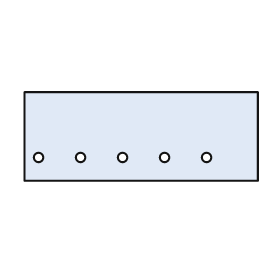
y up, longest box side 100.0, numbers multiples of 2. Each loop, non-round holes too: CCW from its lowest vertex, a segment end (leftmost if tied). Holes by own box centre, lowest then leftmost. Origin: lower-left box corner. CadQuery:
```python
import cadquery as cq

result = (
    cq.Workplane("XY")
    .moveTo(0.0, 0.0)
    .lineTo(100.0, 0.0)
    .lineTo(100.0, 38.0)
    .lineTo(0.0, 38.0)
    .close()
    .moveTo(6.0, 10.0)
    .circle(2.0)
    .moveTo(24.0, 10.0)
    .circle(2.0)
    .moveTo(42.0, 10.0)
    .circle(2.0)
    .moveTo(60.0, 10.0)
    .circle(2.0)
    .moveTo(78.0, 10.0)
    .circle(2.0)
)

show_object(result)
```